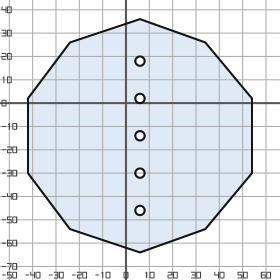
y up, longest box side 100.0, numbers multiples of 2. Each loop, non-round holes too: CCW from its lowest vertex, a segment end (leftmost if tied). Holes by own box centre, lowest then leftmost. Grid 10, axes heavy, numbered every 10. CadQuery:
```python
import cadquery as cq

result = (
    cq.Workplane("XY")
    .moveTo(6.0, -64.0)
    .lineTo(34.0, -54.0)
    .lineTo(54.0, -30.0)
    .lineTo(54.0, 2.0)
    .lineTo(34.0, 26.0)
    .lineTo(6.0, 36.0)
    .lineTo(-24.0, 26.0)
    .lineTo(-42.0, 2.0)
    .lineTo(-42.0, -30.0)
    .lineTo(-24.0, -54.0)
    .close()
    .moveTo(6.0, -46.0)
    .circle(2.0)
    .moveTo(6.0, -30.0)
    .circle(2.0)
    .moveTo(6.0, -14.0)
    .circle(2.0)
    .moveTo(6.0, 2.0)
    .circle(2.0)
    .moveTo(6.0, 18.0)
    .circle(2.0)
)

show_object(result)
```